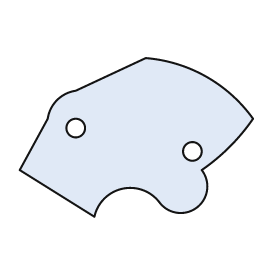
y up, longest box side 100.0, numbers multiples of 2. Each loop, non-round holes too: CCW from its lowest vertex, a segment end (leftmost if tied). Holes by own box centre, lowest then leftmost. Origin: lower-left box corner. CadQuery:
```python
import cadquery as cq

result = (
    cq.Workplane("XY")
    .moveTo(32.0, 0.0)
    .threePointArc((44.0, 12.0), (60.0, 6.0))
    .threePointArc((76.0, 4.0), (78.0, 20.0))
    .threePointArc((90.0, 30.0), (100.0, 42.0))
    .threePointArc((80.0, 60.0), (54.0, 68.0))
    .lineTo(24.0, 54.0)
    .threePointArc((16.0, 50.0), (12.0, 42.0))
    .lineTo(0.0, 20.0)
    .close()
    .moveTo(74.0, 28.0)
    .circle(4.0)
    .moveTo(24.0, 38.0)
    .circle(4.0)
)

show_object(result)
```